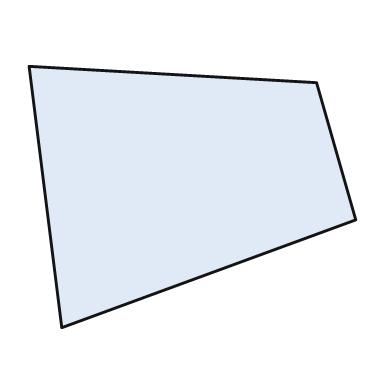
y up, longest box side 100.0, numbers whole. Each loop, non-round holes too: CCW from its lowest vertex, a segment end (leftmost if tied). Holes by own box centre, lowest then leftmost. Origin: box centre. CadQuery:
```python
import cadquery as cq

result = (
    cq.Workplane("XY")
    .moveTo(-40.0, -40.0)
    .lineTo(50.0, -7.0)
    .lineTo(38.0, 35.0)
    .lineTo(-50.0, 40.0)
    .close()
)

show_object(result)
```